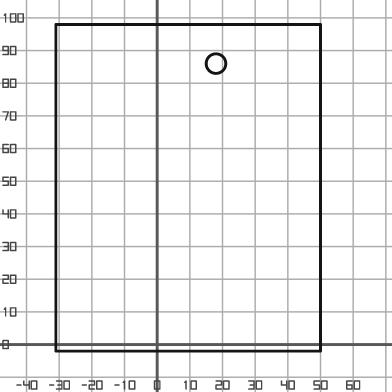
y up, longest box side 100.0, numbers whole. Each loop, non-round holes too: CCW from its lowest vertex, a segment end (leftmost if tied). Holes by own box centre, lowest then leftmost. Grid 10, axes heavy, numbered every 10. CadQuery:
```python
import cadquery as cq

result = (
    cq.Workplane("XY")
    .moveTo(-31.0, -2.0)
    .lineTo(50.0, -2.0)
    .lineTo(50.0, 98.0)
    .lineTo(-31.0, 98.0)
    .close()
    .moveTo(18.0, 86.0)
    .circle(3.0)
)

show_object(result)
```